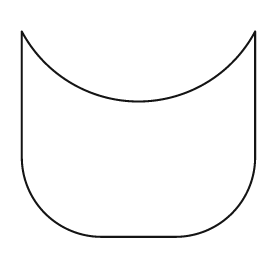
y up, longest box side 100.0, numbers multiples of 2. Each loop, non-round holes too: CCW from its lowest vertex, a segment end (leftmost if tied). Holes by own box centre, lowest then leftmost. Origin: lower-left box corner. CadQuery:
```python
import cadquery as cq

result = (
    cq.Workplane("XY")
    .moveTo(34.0, 0.0)
    .lineTo(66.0, 0.0)
    .threePointArc((90.0, 10.0), (100.0, 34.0))
    .lineTo(100.0, 88.0)
    .threePointArc((50.0, 58.0), (0.0, 88.0))
    .lineTo(0.0, 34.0)
    .threePointArc((10.0, 10.0), (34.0, 0.0))
    .close()
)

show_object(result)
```